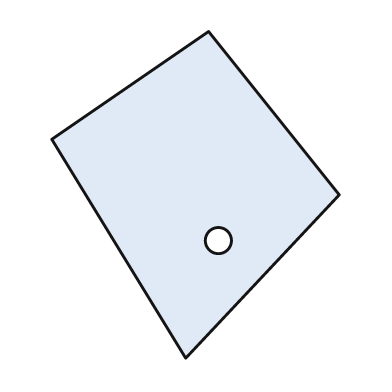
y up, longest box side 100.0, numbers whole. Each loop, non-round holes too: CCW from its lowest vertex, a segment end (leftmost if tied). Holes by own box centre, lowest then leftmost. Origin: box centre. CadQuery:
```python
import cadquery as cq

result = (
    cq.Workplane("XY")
    .moveTo(-3.0, -50.0)
    .lineTo(44.0, 0.0)
    .lineTo(4.0, 50.0)
    .lineTo(-44.0, 17.0)
    .close()
    .moveTo(7.0, -14.0)
    .circle(4.0)
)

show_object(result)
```